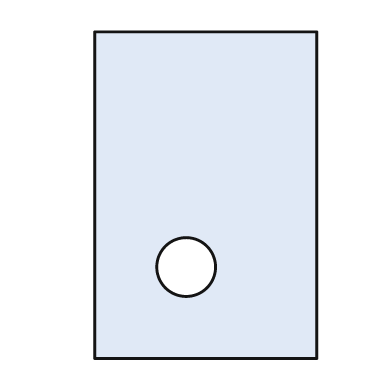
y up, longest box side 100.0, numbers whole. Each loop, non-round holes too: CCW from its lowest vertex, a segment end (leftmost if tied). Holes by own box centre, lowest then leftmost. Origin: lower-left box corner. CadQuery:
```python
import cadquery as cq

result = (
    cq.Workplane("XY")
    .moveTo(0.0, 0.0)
    .lineTo(68.0, 0.0)
    .lineTo(68.0, 100.0)
    .lineTo(0.0, 100.0)
    .close()
    .moveTo(28.0, 28.0)
    .circle(9.0)
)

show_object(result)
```